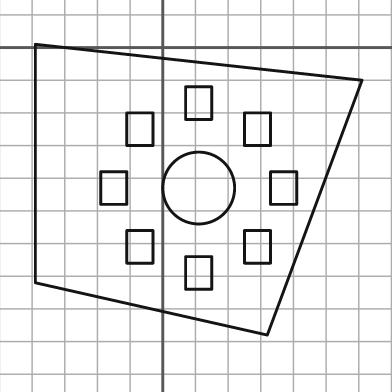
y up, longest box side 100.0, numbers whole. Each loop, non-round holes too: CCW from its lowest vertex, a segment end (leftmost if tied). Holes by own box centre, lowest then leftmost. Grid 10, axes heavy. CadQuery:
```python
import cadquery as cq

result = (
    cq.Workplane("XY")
    .moveTo(32.0, -88.0)
    .lineTo(61.0, -10.0)
    .lineTo(-39.0, 1.0)
    .lineTo(-39.0, -72.0)
    .close()
    .moveTo(7.0, -74.0)
    .lineTo(15.0, -74.0)
    .lineTo(15.0, -64.0)
    .lineTo(7.0, -64.0)
    .close()
    .moveTo(-11.0, -66.0)
    .lineTo(-3.0, -66.0)
    .lineTo(-3.0, -56.0)
    .lineTo(-11.0, -56.0)
    .close()
    .moveTo(25.0, -66.0)
    .lineTo(33.0, -66.0)
    .lineTo(33.0, -56.0)
    .lineTo(25.0, -56.0)
    .close()
    .moveTo(-19.0, -48.0)
    .lineTo(-11.0, -48.0)
    .lineTo(-11.0, -38.0)
    .lineTo(-19.0, -38.0)
    .close()
    .moveTo(11.0, -43.0)
    .circle(11.0)
    .moveTo(33.0, -48.0)
    .lineTo(41.0, -48.0)
    .lineTo(41.0, -38.0)
    .lineTo(33.0, -38.0)
    .close()
    .moveTo(-11.0, -30.0)
    .lineTo(-3.0, -30.0)
    .lineTo(-3.0, -20.0)
    .lineTo(-11.0, -20.0)
    .close()
    .moveTo(25.0, -30.0)
    .lineTo(33.0, -30.0)
    .lineTo(33.0, -20.0)
    .lineTo(25.0, -20.0)
    .close()
    .moveTo(7.0, -22.0)
    .lineTo(15.0, -22.0)
    .lineTo(15.0, -12.0)
    .lineTo(7.0, -12.0)
    .close()
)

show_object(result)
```